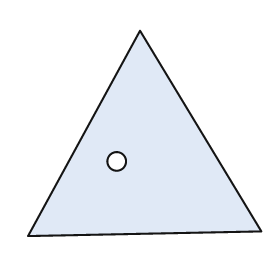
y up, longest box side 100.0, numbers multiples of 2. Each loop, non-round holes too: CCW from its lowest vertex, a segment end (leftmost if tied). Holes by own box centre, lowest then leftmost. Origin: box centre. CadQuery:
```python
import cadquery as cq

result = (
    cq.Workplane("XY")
    .moveTo(-50.0, -44.0)
    .lineTo(50.0, -42.0)
    .lineTo(-2.0, 44.0)
    .close()
    .moveTo(-12.0, -12.0)
    .circle(4.0)
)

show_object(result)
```